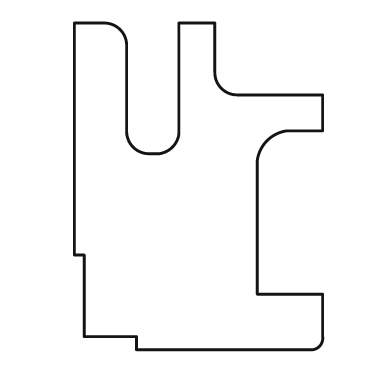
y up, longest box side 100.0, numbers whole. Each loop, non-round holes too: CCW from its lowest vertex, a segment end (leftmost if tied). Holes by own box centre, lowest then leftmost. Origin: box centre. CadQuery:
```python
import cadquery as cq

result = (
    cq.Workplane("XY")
    .moveTo(-19.0, -50.0)
    .lineTo(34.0, -50.0)
    .threePointArc((37.0, -49.0), (38.0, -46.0))
    .lineTo(38.0, -33.0)
    .lineTo(18.0, -33.0)
    .lineTo(18.0, 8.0)
    .threePointArc((21.0, 14.0), (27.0, 17.0))
    .lineTo(38.0, 17.0)
    .lineTo(38.0, 28.0)
    .lineTo(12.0, 28.0)
    .threePointArc((7.0, 30.0), (5.0, 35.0))
    .lineTo(5.0, 50.0)
    .lineTo(-6.0, 50.0)
    .lineTo(-6.0, 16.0)
    .threePointArc((-8.0, 12.0), (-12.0, 10.0))
    .lineTo(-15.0, 10.0)
    .threePointArc((-20.0, 12.0), (-22.0, 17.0))
    .lineTo(-22.0, 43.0)
    .threePointArc((-24.0, 48.0), (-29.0, 50.0))
    .lineTo(-38.0, 50.0)
    .lineTo(-38.0, -21.0)
    .lineTo(-35.0, -21.0)
    .lineTo(-35.0, -46.0)
    .lineTo(-19.0, -46.0)
    .close()
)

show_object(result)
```